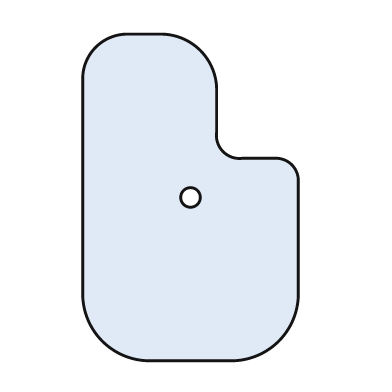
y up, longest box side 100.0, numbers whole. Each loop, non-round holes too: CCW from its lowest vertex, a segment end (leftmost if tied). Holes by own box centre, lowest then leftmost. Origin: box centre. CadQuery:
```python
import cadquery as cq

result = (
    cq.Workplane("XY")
    .moveTo(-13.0, -50.0)
    .lineTo(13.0, -50.0)
    .threePointArc((27.0, -44.0), (33.0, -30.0))
    .lineTo(33.0, 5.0)
    .threePointArc((31.0, 10.0), (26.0, 12.0))
    .lineTo(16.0, 12.0)
    .threePointArc((10.0, 14.0), (8.0, 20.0))
    .lineTo(8.0, 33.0)
    .threePointArc((3.0, 45.0), (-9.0, 50.0))
    .lineTo(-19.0, 50.0)
    .threePointArc((-29.0, 46.0), (-33.0, 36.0))
    .lineTo(-33.0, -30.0)
    .threePointArc((-27.0, -44.0), (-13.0, -50.0))
    .close()
    .moveTo(0.0, 0.0)
    .circle(3.0)
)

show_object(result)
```